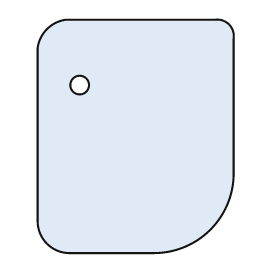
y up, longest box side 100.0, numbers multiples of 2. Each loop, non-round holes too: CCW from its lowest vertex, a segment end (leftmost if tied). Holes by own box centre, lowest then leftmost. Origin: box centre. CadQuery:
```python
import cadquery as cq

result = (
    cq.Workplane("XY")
    .moveTo(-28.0, -50.0)
    .lineTo(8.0, -50.0)
    .threePointArc((32.0, -40.0), (42.0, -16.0))
    .lineTo(42.0, 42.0)
    .threePointArc((40.0, 48.0), (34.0, 50.0))
    .lineTo(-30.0, 50.0)
    .threePointArc((-38.0, 46.0), (-42.0, 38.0))
    .lineTo(-42.0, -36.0)
    .threePointArc((-38.0, -46.0), (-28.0, -50.0))
    .close()
    .moveTo(-24.0, 22.0)
    .circle(4.0)
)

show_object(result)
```